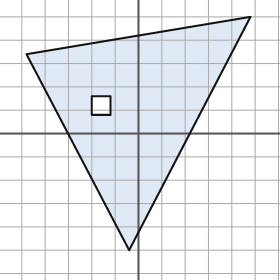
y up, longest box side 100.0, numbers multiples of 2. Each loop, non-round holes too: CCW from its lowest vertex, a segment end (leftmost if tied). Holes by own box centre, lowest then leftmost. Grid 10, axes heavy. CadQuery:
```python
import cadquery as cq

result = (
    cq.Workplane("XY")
    .moveTo(-4.0, -50.0)
    .lineTo(48.0, 50.0)
    .lineTo(-48.0, 34.0)
    .close()
    .moveTo(-20.0, 8.0)
    .lineTo(-12.0, 8.0)
    .lineTo(-12.0, 16.0)
    .lineTo(-20.0, 16.0)
    .close()
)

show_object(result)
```